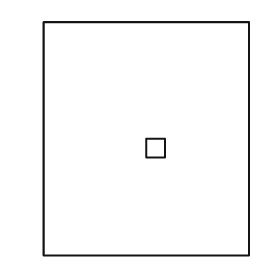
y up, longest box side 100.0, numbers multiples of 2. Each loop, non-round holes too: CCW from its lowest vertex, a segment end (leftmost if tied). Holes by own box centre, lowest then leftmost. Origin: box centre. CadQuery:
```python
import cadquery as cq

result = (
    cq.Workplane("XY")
    .moveTo(-44.0, -50.0)
    .lineTo(44.0, -50.0)
    .lineTo(44.0, 50.0)
    .lineTo(-44.0, 50.0)
    .close()
    .moveTo(0.0, -8.0)
    .lineTo(8.0, -8.0)
    .lineTo(8.0, 0.0)
    .lineTo(0.0, 0.0)
    .close()
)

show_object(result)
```